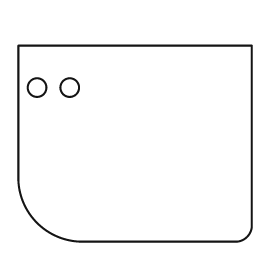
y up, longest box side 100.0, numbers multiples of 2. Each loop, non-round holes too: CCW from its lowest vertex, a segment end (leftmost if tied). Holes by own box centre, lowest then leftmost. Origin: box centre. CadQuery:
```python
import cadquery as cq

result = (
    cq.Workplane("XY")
    .moveTo(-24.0, -42.0)
    .lineTo(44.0, -42.0)
    .threePointArc((48.0, -40.0), (50.0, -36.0))
    .lineTo(50.0, 42.0)
    .lineTo(-50.0, 42.0)
    .lineTo(-50.0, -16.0)
    .threePointArc((-42.0, -34.0), (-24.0, -42.0))
    .close()
    .moveTo(-42.0, 24.0)
    .circle(4.0)
    .moveTo(-28.0, 24.0)
    .circle(4.0)
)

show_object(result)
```